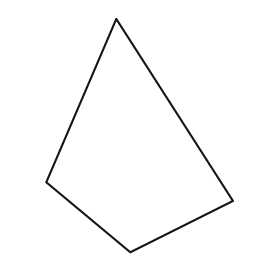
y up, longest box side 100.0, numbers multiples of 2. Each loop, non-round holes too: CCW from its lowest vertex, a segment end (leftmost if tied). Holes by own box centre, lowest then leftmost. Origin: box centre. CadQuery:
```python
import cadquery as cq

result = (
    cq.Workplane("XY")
    .moveTo(-4.0, -50.0)
    .lineTo(40.0, -28.0)
    .lineTo(-10.0, 50.0)
    .lineTo(-40.0, -20.0)
    .close()
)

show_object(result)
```